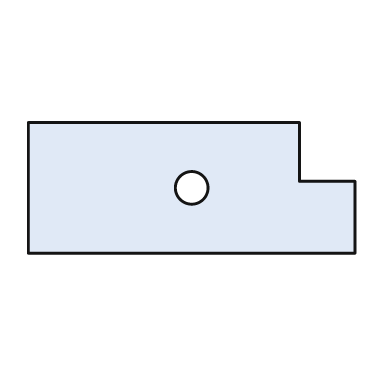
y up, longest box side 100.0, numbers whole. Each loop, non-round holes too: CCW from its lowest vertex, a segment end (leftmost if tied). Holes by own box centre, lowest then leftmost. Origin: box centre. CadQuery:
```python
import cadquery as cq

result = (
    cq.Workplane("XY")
    .moveTo(-50.0, -20.0)
    .lineTo(50.0, -20.0)
    .lineTo(50.0, 2.0)
    .lineTo(33.0, 2.0)
    .lineTo(33.0, 20.0)
    .lineTo(-50.0, 20.0)
    .close()
    .moveTo(0.0, 0.0)
    .circle(5.0)
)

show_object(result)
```